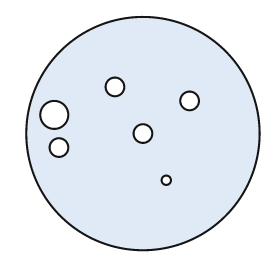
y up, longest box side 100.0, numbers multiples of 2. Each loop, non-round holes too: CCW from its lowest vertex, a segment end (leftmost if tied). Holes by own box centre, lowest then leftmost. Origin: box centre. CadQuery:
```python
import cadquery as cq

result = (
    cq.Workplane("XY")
    .moveTo(0.0, 0.0)
    .circle(50.0)
    .moveTo(10.0, -20.0)
    .circle(2.0)
    .moveTo(-36.0, -6.0)
    .circle(4.0)
    .moveTo(0.0, 0.0)
    .circle(4.0)
    .moveTo(-38.0, 8.0)
    .circle(6.0)
    .moveTo(20.0, 14.0)
    .circle(4.0)
    .moveTo(-12.0, 20.0)
    .circle(4.0)
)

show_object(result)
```